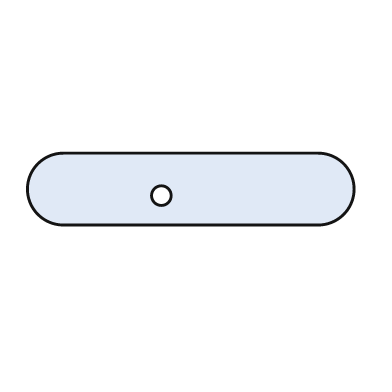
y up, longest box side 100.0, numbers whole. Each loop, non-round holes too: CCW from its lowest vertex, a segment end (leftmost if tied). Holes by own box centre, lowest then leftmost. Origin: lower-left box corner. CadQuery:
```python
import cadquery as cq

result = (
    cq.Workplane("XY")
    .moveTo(11.0, 0.0)
    .lineTo(89.0, 0.0)
    .threePointArc((100.0, 11.0), (89.0, 22.0))
    .lineTo(11.0, 22.0)
    .threePointArc((0.0, 11.0), (11.0, 0.0))
    .close()
    .moveTo(41.0, 9.0)
    .circle(3.0)
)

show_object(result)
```